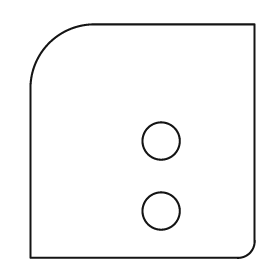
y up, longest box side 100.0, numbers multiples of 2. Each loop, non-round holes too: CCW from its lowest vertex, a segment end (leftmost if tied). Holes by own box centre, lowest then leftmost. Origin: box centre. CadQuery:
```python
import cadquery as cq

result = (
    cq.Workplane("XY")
    .moveTo(-48.0, -50.0)
    .lineTo(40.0, -50.0)
    .threePointArc((46.0, -48.0), (48.0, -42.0))
    .lineTo(48.0, 50.0)
    .lineTo(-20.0, 50.0)
    .threePointArc((-40.0, 42.0), (-48.0, 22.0))
    .close()
    .moveTo(8.0, -30.0)
    .circle(8.0)
    .moveTo(8.0, 0.0)
    .circle(8.0)
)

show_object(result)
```